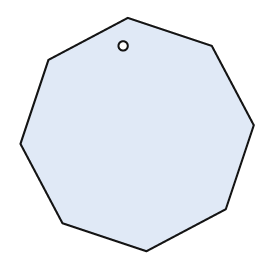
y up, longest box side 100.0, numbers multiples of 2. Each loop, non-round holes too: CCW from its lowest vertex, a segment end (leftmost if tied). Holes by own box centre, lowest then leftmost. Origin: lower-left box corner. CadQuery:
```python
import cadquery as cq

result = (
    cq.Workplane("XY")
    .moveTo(54.0, 0.0)
    .lineTo(88.0, 18.0)
    .lineTo(100.0, 54.0)
    .lineTo(82.0, 88.0)
    .lineTo(46.0, 100.0)
    .lineTo(12.0, 82.0)
    .lineTo(0.0, 46.0)
    .lineTo(18.0, 12.0)
    .close()
    .moveTo(44.0, 88.0)
    .circle(2.0)
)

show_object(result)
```